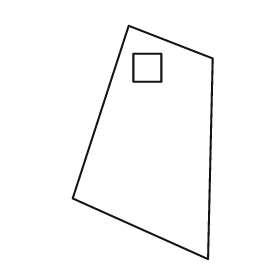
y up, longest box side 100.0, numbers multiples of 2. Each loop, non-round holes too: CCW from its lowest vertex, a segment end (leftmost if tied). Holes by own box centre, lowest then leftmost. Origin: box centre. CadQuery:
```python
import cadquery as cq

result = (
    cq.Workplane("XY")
    .moveTo(28.0, -50.0)
    .lineTo(30.0, 36.0)
    .lineTo(-6.0, 50.0)
    .lineTo(-30.0, -24.0)
    .close()
    .moveTo(-4.0, 26.0)
    .lineTo(8.0, 26.0)
    .lineTo(8.0, 38.0)
    .lineTo(-4.0, 38.0)
    .close()
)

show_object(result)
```